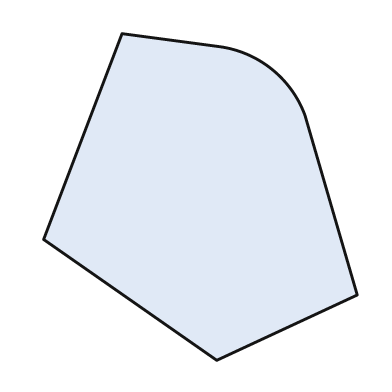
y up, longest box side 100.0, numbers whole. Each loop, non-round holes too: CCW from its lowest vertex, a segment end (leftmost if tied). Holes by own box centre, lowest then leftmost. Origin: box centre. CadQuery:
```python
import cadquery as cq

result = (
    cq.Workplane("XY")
    .moveTo(5.0, -50.0)
    .lineTo(48.0, -30.0)
    .lineTo(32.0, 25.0)
    .threePointArc((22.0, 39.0), (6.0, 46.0))
    .lineTo(-24.0, 50.0)
    .lineTo(-48.0, -13.0)
    .close()
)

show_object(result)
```